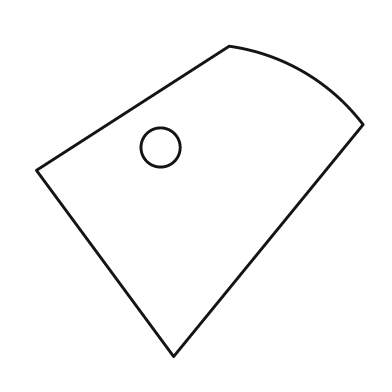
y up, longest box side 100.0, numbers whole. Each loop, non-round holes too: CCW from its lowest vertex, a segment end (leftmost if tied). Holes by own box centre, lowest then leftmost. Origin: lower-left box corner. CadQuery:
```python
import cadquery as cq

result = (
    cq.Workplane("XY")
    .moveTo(42.0, 0.0)
    .lineTo(100.0, 71.0)
    .threePointArc((82.0, 87.0), (59.0, 95.0))
    .lineTo(0.0, 57.0)
    .close()
    .moveTo(38.0, 64.0)
    .circle(6.0)
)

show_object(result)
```